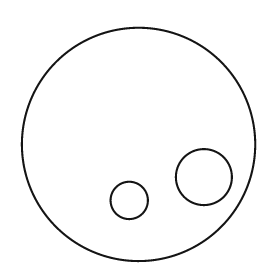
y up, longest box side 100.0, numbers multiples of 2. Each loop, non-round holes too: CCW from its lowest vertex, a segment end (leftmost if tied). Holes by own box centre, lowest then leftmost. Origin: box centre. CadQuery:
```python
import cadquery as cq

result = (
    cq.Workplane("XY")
    .moveTo(0.0, 0.0)
    .circle(50.0)
    .moveTo(-4.0, -24.0)
    .circle(8.0)
    .moveTo(28.0, -14.0)
    .circle(12.0)
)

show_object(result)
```